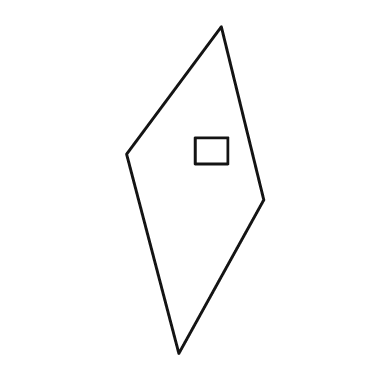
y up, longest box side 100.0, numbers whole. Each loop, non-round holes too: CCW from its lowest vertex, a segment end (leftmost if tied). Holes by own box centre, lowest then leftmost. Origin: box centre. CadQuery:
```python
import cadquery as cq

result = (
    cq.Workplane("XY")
    .moveTo(-5.0, -50.0)
    .lineTo(21.0, -3.0)
    .lineTo(8.0, 50.0)
    .lineTo(-21.0, 11.0)
    .close()
    .moveTo(0.0, 8.0)
    .lineTo(10.0, 8.0)
    .lineTo(10.0, 16.0)
    .lineTo(0.0, 16.0)
    .close()
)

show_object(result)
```